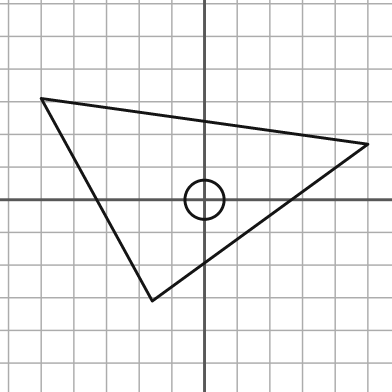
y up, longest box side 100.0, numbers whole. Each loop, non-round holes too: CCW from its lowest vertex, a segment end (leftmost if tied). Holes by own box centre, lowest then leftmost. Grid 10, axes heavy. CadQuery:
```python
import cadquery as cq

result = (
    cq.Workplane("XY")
    .moveTo(-16.0, -31.0)
    .lineTo(50.0, 17.0)
    .lineTo(-50.0, 31.0)
    .close()
    .moveTo(0.0, 0.0)
    .circle(6.0)
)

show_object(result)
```